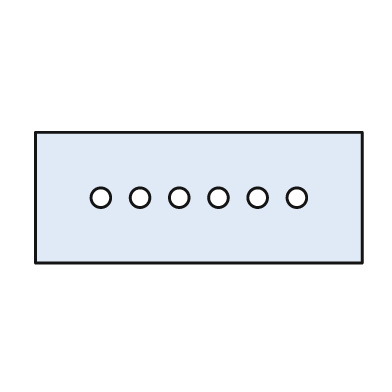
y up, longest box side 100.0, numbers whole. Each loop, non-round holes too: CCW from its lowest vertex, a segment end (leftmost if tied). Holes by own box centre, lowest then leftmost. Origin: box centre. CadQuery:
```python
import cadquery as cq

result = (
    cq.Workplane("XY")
    .moveTo(-50.0, -20.0)
    .lineTo(50.0, -20.0)
    .lineTo(50.0, 20.0)
    .lineTo(-50.0, 20.0)
    .close()
    .moveTo(-30.0, 0.0)
    .circle(3.0)
    .moveTo(-18.0, 0.0)
    .circle(3.0)
    .moveTo(-6.0, 0.0)
    .circle(3.0)
    .moveTo(6.0, 0.0)
    .circle(3.0)
    .moveTo(18.0, 0.0)
    .circle(3.0)
    .moveTo(30.0, 0.0)
    .circle(3.0)
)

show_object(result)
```